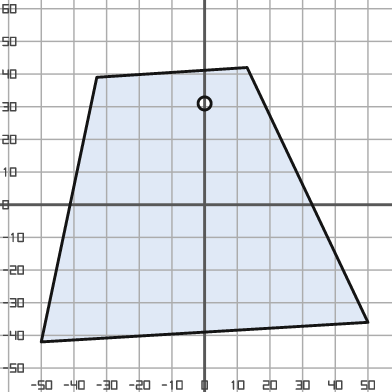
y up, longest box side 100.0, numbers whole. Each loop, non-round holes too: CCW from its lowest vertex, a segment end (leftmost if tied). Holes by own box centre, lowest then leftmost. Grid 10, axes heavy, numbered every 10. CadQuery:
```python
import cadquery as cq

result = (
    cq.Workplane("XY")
    .moveTo(-50.0, -42.0)
    .lineTo(50.0, -36.0)
    .lineTo(13.0, 42.0)
    .lineTo(-33.0, 39.0)
    .close()
    .moveTo(0.0, 31.0)
    .circle(2.0)
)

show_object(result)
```